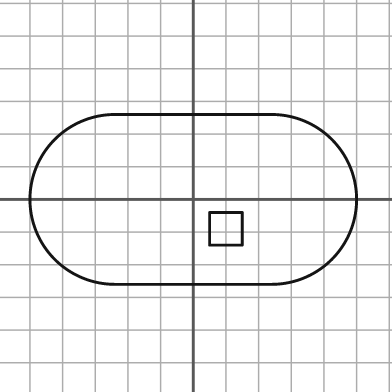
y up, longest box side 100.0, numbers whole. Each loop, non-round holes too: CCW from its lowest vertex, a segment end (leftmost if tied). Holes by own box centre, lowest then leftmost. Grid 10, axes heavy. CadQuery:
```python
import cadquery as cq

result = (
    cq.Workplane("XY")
    .moveTo(-24.0, -26.0)
    .lineTo(24.0, -26.0)
    .threePointArc((50.0, 0.0), (24.0, 26.0))
    .lineTo(-24.0, 26.0)
    .threePointArc((-50.0, 0.0), (-24.0, -26.0))
    .close()
    .moveTo(5.0, -14.0)
    .lineTo(15.0, -14.0)
    .lineTo(15.0, -4.0)
    .lineTo(5.0, -4.0)
    .close()
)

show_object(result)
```